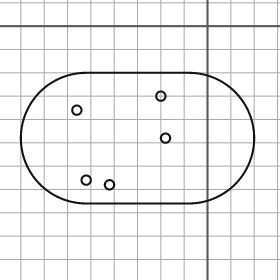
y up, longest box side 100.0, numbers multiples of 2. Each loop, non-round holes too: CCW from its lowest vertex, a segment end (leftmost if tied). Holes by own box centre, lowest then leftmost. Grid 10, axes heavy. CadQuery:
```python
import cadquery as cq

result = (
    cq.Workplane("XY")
    .moveTo(-52.0, -76.0)
    .lineTo(-8.0, -76.0)
    .threePointArc((20.0, -48.0), (-8.0, -20.0))
    .lineTo(-52.0, -20.0)
    .threePointArc((-80.0, -48.0), (-52.0, -76.0))
    .close()
    .moveTo(-42.0, -68.0)
    .circle(2.0)
    .moveTo(-52.0, -66.0)
    .circle(2.0)
    .moveTo(-18.0, -48.0)
    .circle(2.0)
    .moveTo(-56.0, -36.0)
    .circle(2.0)
    .moveTo(-20.0, -30.0)
    .circle(2.0)
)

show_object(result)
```